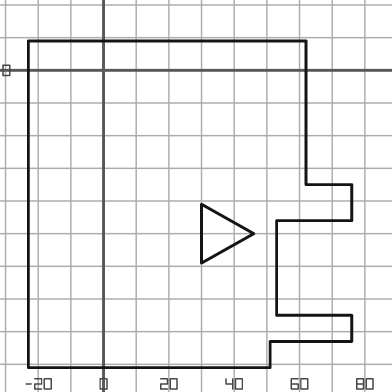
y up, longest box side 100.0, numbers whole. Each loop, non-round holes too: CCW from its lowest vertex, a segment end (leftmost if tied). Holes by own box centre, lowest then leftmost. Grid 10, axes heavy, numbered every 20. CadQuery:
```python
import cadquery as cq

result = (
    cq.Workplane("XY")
    .moveTo(-23.0, -91.0)
    .lineTo(51.0, -91.0)
    .lineTo(51.0, -83.0)
    .lineTo(76.0, -83.0)
    .lineTo(76.0, -75.0)
    .lineTo(53.0, -75.0)
    .lineTo(53.0, -46.0)
    .lineTo(76.0, -46.0)
    .lineTo(76.0, -35.0)
    .lineTo(62.0, -35.0)
    .lineTo(62.0, 9.0)
    .lineTo(-23.0, 9.0)
    .close()
    .moveTo(30.0, -59.0)
    .lineTo(46.0, -50.0)
    .lineTo(30.0, -41.0)
    .close()
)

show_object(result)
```